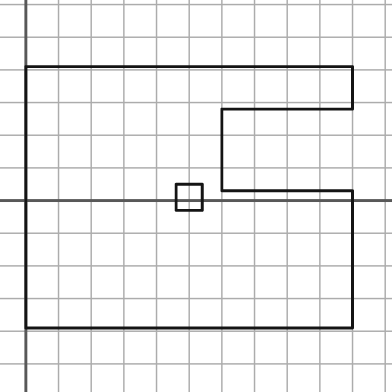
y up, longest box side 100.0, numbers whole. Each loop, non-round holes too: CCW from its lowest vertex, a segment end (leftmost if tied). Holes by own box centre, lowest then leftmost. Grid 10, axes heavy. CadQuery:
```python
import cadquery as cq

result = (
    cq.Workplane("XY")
    .moveTo(0.0, -39.0)
    .lineTo(100.0, -39.0)
    .lineTo(100.0, 3.0)
    .lineTo(60.0, 3.0)
    .lineTo(60.0, 28.0)
    .lineTo(100.0, 28.0)
    .lineTo(100.0, 41.0)
    .lineTo(0.0, 41.0)
    .close()
    .moveTo(46.0, -3.0)
    .lineTo(54.0, -3.0)
    .lineTo(54.0, 5.0)
    .lineTo(46.0, 5.0)
    .close()
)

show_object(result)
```